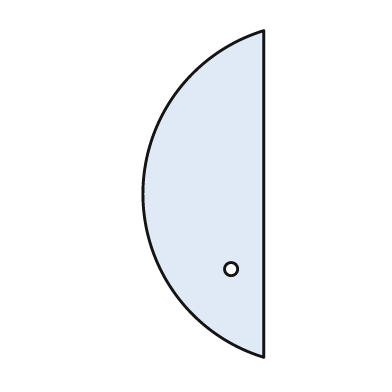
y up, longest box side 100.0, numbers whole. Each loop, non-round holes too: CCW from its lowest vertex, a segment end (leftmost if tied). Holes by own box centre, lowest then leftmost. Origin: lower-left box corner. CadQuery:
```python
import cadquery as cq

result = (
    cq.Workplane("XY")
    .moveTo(37.0, 0.0)
    .lineTo(37.0, 100.0)
    .threePointArc((0.0, 50.0), (37.0, 0.0))
    .close()
    .moveTo(27.0, 27.0)
    .circle(2.0)
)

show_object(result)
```